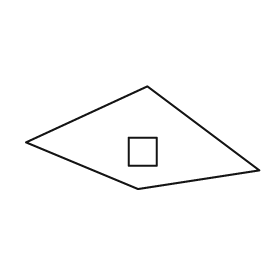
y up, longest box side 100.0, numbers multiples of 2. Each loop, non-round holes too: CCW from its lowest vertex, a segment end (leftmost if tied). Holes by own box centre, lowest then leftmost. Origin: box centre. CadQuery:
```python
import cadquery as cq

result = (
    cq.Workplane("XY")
    .moveTo(-2.0, -22.0)
    .lineTo(50.0, -14.0)
    .lineTo(2.0, 22.0)
    .lineTo(-50.0, -2.0)
    .close()
    .moveTo(-6.0, -12.0)
    .lineTo(6.0, -12.0)
    .lineTo(6.0, 0.0)
    .lineTo(-6.0, 0.0)
    .close()
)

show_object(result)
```